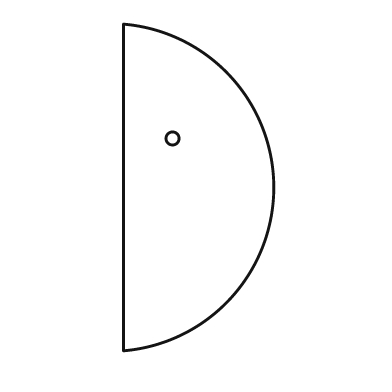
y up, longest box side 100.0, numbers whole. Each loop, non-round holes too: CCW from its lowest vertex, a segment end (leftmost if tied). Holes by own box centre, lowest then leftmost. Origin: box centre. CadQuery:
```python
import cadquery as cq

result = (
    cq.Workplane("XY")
    .moveTo(-23.0, -50.0)
    .threePointArc((23.0, 0.0), (-23.0, 50.0))
    .close()
    .moveTo(-8.0, 15.0)
    .circle(2.0)
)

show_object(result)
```